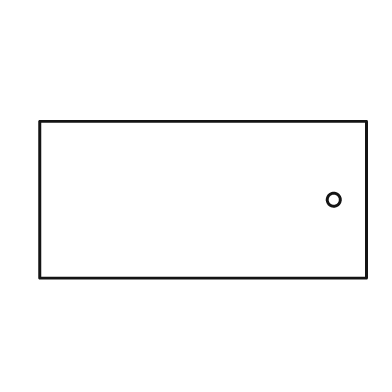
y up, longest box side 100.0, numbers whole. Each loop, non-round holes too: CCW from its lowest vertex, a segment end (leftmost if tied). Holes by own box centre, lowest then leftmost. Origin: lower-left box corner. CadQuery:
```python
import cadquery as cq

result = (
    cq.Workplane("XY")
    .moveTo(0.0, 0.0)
    .lineTo(100.0, 0.0)
    .lineTo(100.0, 48.0)
    .lineTo(0.0, 48.0)
    .close()
    .moveTo(90.0, 24.0)
    .circle(2.0)
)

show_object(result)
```